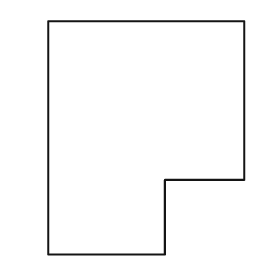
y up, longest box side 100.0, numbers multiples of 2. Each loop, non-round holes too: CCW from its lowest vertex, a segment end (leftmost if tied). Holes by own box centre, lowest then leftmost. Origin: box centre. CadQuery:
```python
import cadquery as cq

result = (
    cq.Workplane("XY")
    .moveTo(-42.0, -50.0)
    .lineTo(8.0, -50.0)
    .lineTo(8.0, -18.0)
    .lineTo(42.0, -18.0)
    .lineTo(42.0, 50.0)
    .lineTo(-42.0, 50.0)
    .close()
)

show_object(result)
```